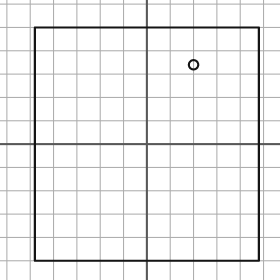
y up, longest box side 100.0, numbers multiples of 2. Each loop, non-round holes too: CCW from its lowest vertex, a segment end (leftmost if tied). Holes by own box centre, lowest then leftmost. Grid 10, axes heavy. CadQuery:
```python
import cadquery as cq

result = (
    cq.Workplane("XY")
    .moveTo(-48.0, -50.0)
    .lineTo(48.0, -50.0)
    .lineTo(48.0, 50.0)
    .lineTo(-48.0, 50.0)
    .close()
    .moveTo(20.0, 34.0)
    .circle(2.0)
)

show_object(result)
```